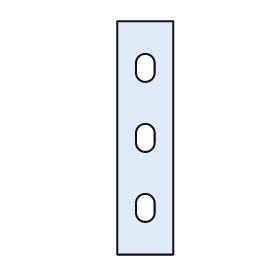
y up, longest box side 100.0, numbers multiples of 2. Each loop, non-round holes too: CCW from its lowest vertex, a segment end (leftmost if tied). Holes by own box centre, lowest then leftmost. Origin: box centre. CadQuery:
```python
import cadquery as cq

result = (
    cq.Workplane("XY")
    .moveTo(-12.0, -50.0)
    .lineTo(12.0, -50.0)
    .lineTo(12.0, 50.0)
    .lineTo(-12.0, 50.0)
    .close()
    .moveTo(-4.0, -32.0)
    .threePointArc((0.0, -36.0), (4.0, -32.0))
    .lineTo(4.0, -28.0)
    .threePointArc((0.0, -24.0), (-4.0, -28.0))
    .close()
    .moveTo(-4.0, -2.0)
    .threePointArc((0.0, -6.0), (4.0, -2.0))
    .lineTo(4.0, 2.0)
    .threePointArc((0.0, 6.0), (-4.0, 2.0))
    .close()
    .moveTo(-4.0, 28.0)
    .threePointArc((0.0, 24.0), (4.0, 28.0))
    .lineTo(4.0, 32.0)
    .threePointArc((0.0, 36.0), (-4.0, 32.0))
    .close()
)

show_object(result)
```